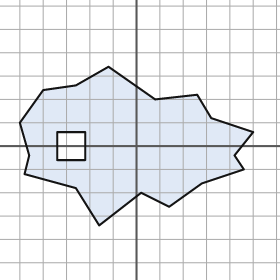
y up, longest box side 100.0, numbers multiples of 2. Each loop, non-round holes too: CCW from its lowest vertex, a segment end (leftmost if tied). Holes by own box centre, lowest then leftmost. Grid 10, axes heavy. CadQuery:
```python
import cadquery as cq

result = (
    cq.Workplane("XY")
    .moveTo(-16.0, -34.0)
    .lineTo(2.0, -20.0)
    .lineTo(14.0, -26.0)
    .lineTo(28.0, -16.0)
    .lineTo(46.0, -10.0)
    .lineTo(42.0, -4.0)
    .lineTo(50.0, 6.0)
    .lineTo(32.0, 12.0)
    .lineTo(26.0, 22.0)
    .lineTo(8.0, 20.0)
    .lineTo(-12.0, 34.0)
    .lineTo(-26.0, 26.0)
    .lineTo(-40.0, 24.0)
    .lineTo(-50.0, 10.0)
    .lineTo(-46.0, -4.0)
    .lineTo(-48.0, -12.0)
    .lineTo(-26.0, -18.0)
    .close()
    .moveTo(-34.0, -6.0)
    .lineTo(-22.0, -6.0)
    .lineTo(-22.0, 6.0)
    .lineTo(-34.0, 6.0)
    .close()
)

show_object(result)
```